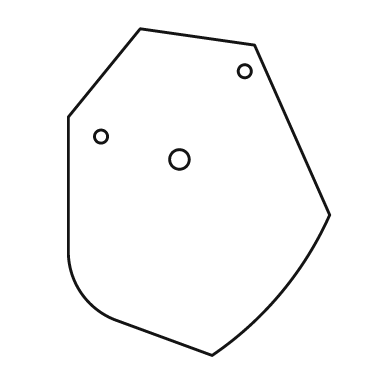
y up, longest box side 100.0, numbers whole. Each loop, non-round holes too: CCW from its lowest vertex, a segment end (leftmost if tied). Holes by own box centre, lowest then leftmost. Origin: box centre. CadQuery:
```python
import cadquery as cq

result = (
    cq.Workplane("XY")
    .moveTo(4.0, -50.0)
    .threePointArc((25.0, -31.0), (40.0, -7.0))
    .lineTo(17.0, 45.0)
    .lineTo(-18.0, 50.0)
    .lineTo(-40.0, 23.0)
    .lineTo(-40.0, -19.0)
    .threePointArc((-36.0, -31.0), (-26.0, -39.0))
    .close()
    .moveTo(-6.0, 10.0)
    .circle(3.0)
    .moveTo(-30.0, 17.0)
    .circle(2.0)
    .moveTo(14.0, 37.0)
    .circle(2.0)
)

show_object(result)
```